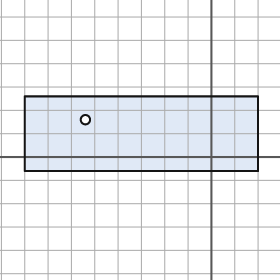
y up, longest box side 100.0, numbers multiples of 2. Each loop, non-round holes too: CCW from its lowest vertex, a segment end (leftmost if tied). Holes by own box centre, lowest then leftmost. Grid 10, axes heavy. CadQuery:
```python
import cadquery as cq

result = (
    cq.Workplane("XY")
    .moveTo(-80.0, -6.0)
    .lineTo(20.0, -6.0)
    .lineTo(20.0, 26.0)
    .lineTo(-80.0, 26.0)
    .close()
    .moveTo(-54.0, 16.0)
    .circle(2.0)
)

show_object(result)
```